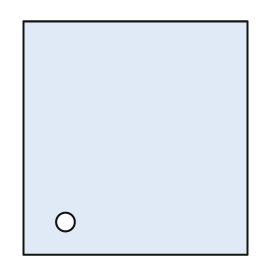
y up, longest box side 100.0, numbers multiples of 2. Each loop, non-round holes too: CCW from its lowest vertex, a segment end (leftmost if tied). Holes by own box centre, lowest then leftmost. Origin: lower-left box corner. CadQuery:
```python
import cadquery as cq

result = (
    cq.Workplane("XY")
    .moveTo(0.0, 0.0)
    .lineTo(96.0, 0.0)
    .lineTo(96.0, 100.0)
    .lineTo(0.0, 100.0)
    .close()
    .moveTo(18.0, 14.0)
    .circle(4.0)
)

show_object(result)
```